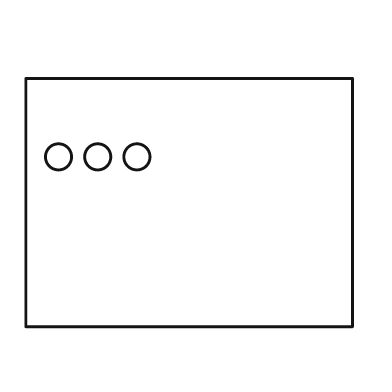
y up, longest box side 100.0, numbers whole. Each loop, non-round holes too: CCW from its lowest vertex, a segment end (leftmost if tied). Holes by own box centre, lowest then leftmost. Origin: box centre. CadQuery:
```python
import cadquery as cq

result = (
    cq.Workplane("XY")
    .moveTo(-50.0, -38.0)
    .lineTo(50.0, -38.0)
    .lineTo(50.0, 38.0)
    .lineTo(-50.0, 38.0)
    .close()
    .moveTo(-40.0, 14.0)
    .circle(4.0)
    .moveTo(-28.0, 14.0)
    .circle(4.0)
    .moveTo(-16.0, 14.0)
    .circle(4.0)
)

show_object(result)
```